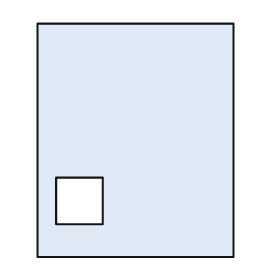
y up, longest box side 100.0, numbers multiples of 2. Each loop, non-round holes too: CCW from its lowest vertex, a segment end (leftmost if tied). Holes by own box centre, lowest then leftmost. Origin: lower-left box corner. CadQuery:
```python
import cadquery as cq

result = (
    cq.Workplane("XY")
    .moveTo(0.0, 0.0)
    .lineTo(84.0, 0.0)
    .lineTo(84.0, 100.0)
    .lineTo(0.0, 100.0)
    .close()
    .moveTo(8.0, 14.0)
    .lineTo(28.0, 14.0)
    .lineTo(28.0, 34.0)
    .lineTo(8.0, 34.0)
    .close()
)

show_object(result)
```